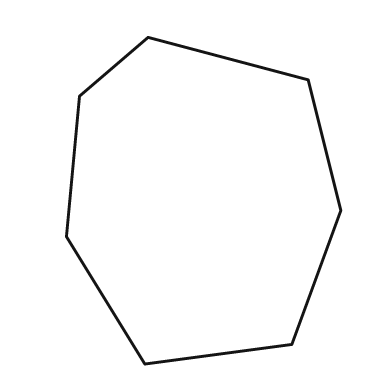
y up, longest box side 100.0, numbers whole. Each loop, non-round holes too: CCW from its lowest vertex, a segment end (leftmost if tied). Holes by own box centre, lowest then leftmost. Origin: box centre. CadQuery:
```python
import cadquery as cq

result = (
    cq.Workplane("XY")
    .moveTo(-18.0, -50.0)
    .lineTo(27.0, -44.0)
    .lineTo(42.0, -3.0)
    .lineTo(32.0, 37.0)
    .lineTo(-17.0, 50.0)
    .lineTo(-38.0, 32.0)
    .lineTo(-42.0, -11.0)
    .close()
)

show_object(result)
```